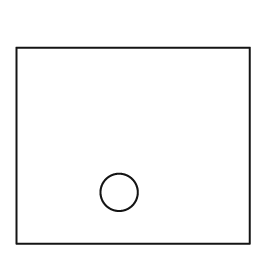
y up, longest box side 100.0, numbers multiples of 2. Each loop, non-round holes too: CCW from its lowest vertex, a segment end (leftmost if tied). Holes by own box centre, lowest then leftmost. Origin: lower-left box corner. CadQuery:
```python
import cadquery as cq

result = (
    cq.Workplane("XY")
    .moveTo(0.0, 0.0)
    .lineTo(100.0, 0.0)
    .lineTo(100.0, 84.0)
    .lineTo(0.0, 84.0)
    .close()
    .moveTo(44.0, 22.0)
    .circle(8.0)
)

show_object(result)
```